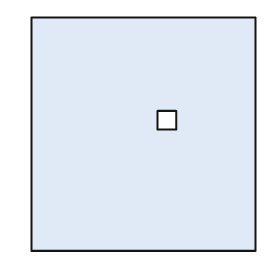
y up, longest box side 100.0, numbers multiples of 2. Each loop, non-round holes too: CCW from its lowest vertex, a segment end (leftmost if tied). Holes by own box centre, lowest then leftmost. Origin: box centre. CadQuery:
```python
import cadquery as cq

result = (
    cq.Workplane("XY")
    .moveTo(-48.0, -50.0)
    .lineTo(48.0, -50.0)
    .lineTo(48.0, 50.0)
    .lineTo(-48.0, 50.0)
    .close()
    .moveTo(6.0, 2.0)
    .lineTo(14.0, 2.0)
    .lineTo(14.0, 10.0)
    .lineTo(6.0, 10.0)
    .close()
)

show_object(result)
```